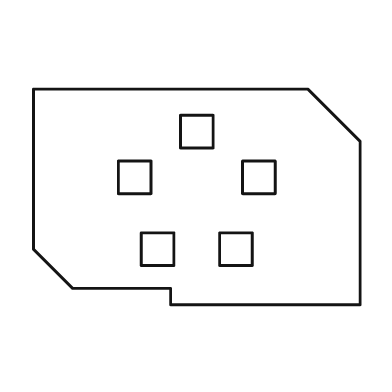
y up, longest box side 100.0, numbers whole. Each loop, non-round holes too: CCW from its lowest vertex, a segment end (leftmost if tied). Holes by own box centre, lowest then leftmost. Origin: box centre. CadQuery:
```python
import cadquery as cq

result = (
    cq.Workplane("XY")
    .moveTo(-8.0, -33.0)
    .lineTo(50.0, -33.0)
    .lineTo(50.0, 17.0)
    .lineTo(34.0, 33.0)
    .lineTo(-50.0, 33.0)
    .lineTo(-50.0, -16.0)
    .lineTo(-38.0, -28.0)
    .lineTo(-8.0, -28.0)
    .close()
    .moveTo(-17.0, -21.0)
    .lineTo(-7.0, -21.0)
    .lineTo(-7.0, -11.0)
    .lineTo(-17.0, -11.0)
    .close()
    .moveTo(7.0, -21.0)
    .lineTo(17.0, -21.0)
    .lineTo(17.0, -11.0)
    .lineTo(7.0, -11.0)
    .close()
    .moveTo(-24.0, 1.0)
    .lineTo(-14.0, 1.0)
    .lineTo(-14.0, 11.0)
    .lineTo(-24.0, 11.0)
    .close()
    .moveTo(14.0, 1.0)
    .lineTo(24.0, 1.0)
    .lineTo(24.0, 11.0)
    .lineTo(14.0, 11.0)
    .close()
    .moveTo(-5.0, 15.0)
    .lineTo(5.0, 15.0)
    .lineTo(5.0, 25.0)
    .lineTo(-5.0, 25.0)
    .close()
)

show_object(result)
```